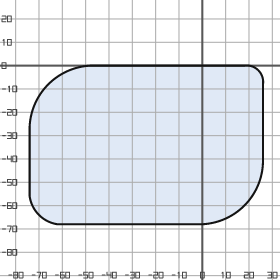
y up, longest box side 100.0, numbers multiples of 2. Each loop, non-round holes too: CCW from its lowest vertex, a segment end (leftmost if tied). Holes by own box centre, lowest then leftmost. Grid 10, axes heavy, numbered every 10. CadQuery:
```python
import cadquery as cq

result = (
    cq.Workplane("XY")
    .moveTo(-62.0, -68.0)
    .lineTo(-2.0, -68.0)
    .threePointArc((18.0, -60.0), (26.0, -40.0))
    .lineTo(26.0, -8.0)
    .threePointArc((24.0, -2.0), (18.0, 0.0))
    .lineTo(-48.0, 0.0)
    .threePointArc((-66.0, -8.0), (-74.0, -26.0))
    .lineTo(-74.0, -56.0)
    .threePointArc((-70.0, -64.0), (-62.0, -68.0))
    .close()
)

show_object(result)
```